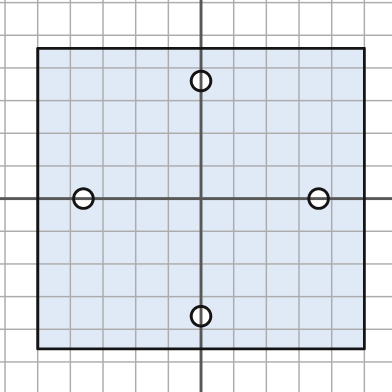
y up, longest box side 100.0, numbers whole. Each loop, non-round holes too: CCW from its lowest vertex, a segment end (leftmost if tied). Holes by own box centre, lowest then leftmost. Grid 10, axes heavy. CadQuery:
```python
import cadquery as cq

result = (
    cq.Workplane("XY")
    .moveTo(-50.0, -46.0)
    .lineTo(50.0, -46.0)
    .lineTo(50.0, 46.0)
    .lineTo(-50.0, 46.0)
    .close()
    .moveTo(0.0, -36.0)
    .circle(3.0)
    .moveTo(-36.0, 0.0)
    .circle(3.0)
    .moveTo(36.0, 0.0)
    .circle(3.0)
    .moveTo(0.0, 36.0)
    .circle(3.0)
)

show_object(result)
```